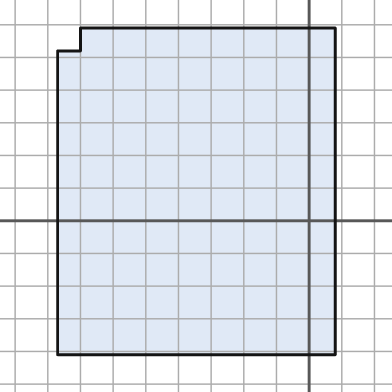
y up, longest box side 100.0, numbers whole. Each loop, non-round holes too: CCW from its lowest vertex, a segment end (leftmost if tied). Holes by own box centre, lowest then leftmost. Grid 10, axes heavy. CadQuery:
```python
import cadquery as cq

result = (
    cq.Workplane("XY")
    .moveTo(-77.0, -41.0)
    .lineTo(8.0, -41.0)
    .lineTo(8.0, 59.0)
    .lineTo(-70.0, 59.0)
    .lineTo(-70.0, 52.0)
    .lineTo(-77.0, 52.0)
    .close()
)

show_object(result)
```